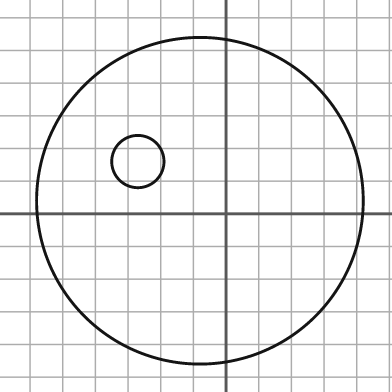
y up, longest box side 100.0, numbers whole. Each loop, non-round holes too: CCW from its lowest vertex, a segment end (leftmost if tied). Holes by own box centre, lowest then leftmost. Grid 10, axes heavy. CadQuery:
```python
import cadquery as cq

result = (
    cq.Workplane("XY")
    .moveTo(-8.0, 4.0)
    .circle(50.0)
    .moveTo(-27.0, 16.0)
    .circle(8.0)
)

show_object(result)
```